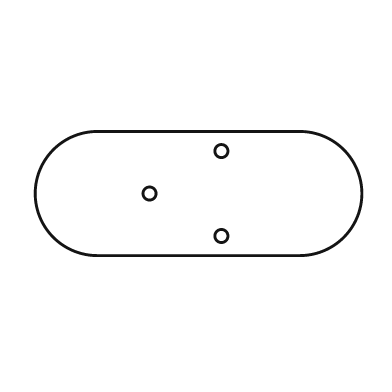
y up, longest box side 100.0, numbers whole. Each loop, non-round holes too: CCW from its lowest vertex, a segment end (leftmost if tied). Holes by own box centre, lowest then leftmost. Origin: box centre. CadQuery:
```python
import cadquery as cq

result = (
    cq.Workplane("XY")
    .moveTo(-31.0, -19.0)
    .lineTo(31.0, -19.0)
    .threePointArc((50.0, 0.0), (31.0, 19.0))
    .lineTo(-31.0, 19.0)
    .threePointArc((-50.0, 0.0), (-31.0, -19.0))
    .close()
    .moveTo(7.0, -13.0)
    .circle(2.0)
    .moveTo(-15.0, 0.0)
    .circle(2.0)
    .moveTo(7.0, 13.0)
    .circle(2.0)
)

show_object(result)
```